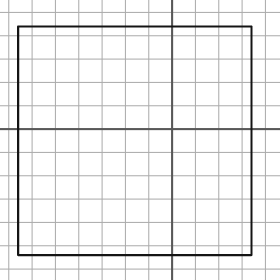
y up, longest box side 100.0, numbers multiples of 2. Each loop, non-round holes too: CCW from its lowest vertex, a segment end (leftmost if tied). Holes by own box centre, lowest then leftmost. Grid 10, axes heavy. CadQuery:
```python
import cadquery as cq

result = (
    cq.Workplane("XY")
    .moveTo(-66.0, -54.0)
    .lineTo(34.0, -54.0)
    .lineTo(34.0, 44.0)
    .lineTo(-66.0, 44.0)
    .close()
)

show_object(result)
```